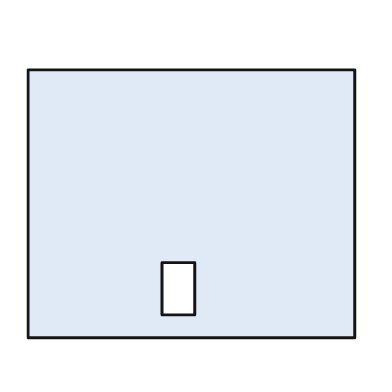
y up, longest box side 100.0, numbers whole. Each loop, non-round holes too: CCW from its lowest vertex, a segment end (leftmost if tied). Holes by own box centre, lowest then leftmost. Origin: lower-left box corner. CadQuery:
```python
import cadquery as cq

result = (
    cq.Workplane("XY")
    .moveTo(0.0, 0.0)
    .lineTo(100.0, 0.0)
    .lineTo(100.0, 82.0)
    .lineTo(0.0, 82.0)
    .close()
    .moveTo(41.0, 7.0)
    .lineTo(51.0, 7.0)
    .lineTo(51.0, 23.0)
    .lineTo(41.0, 23.0)
    .close()
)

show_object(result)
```